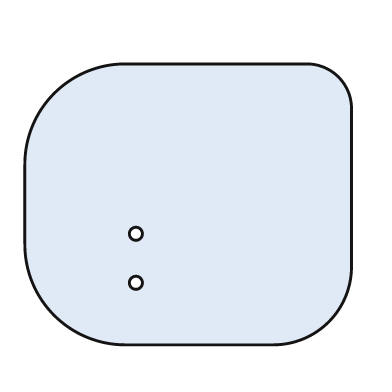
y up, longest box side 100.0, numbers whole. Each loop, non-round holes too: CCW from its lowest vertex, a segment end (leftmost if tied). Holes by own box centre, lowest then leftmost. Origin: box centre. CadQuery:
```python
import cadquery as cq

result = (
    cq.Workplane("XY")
    .moveTo(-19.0, -43.0)
    .lineTo(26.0, -43.0)
    .threePointArc((43.0, -36.0), (50.0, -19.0))
    .lineTo(50.0, 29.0)
    .threePointArc((46.0, 39.0), (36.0, 43.0))
    .lineTo(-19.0, 43.0)
    .threePointArc((-41.0, 34.0), (-50.0, 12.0))
    .lineTo(-50.0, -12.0)
    .threePointArc((-41.0, -34.0), (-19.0, -43.0))
    .close()
    .moveTo(-16.0, -24.0)
    .circle(2.0)
    .moveTo(-16.0, -9.0)
    .circle(2.0)
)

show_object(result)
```